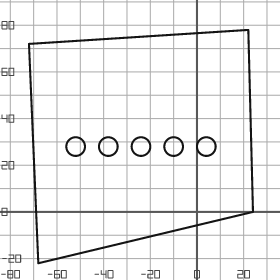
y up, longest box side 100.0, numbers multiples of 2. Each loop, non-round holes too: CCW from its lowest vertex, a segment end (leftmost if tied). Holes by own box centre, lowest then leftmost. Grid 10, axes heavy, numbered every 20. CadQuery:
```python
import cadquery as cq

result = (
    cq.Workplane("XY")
    .moveTo(-68.0, -22.0)
    .lineTo(24.0, 0.0)
    .lineTo(22.0, 78.0)
    .lineTo(-72.0, 72.0)
    .close()
    .moveTo(-52.0, 28.0)
    .circle(4.0)
    .moveTo(-38.0, 28.0)
    .circle(4.0)
    .moveTo(-24.0, 28.0)
    .circle(4.0)
    .moveTo(-10.0, 28.0)
    .circle(4.0)
    .moveTo(4.0, 28.0)
    .circle(4.0)
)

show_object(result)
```